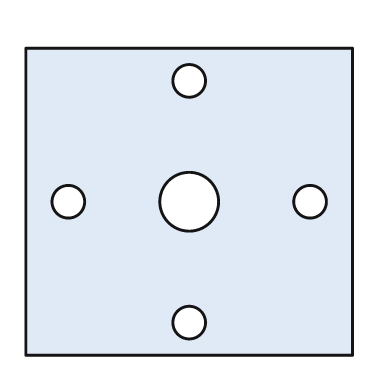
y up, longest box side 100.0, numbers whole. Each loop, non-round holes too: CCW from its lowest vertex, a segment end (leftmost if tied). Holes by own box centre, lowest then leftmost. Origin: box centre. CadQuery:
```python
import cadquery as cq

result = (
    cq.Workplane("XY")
    .moveTo(-50.0, -47.0)
    .lineTo(50.0, -47.0)
    .lineTo(50.0, 47.0)
    .lineTo(-50.0, 47.0)
    .close()
    .moveTo(0.0, -37.0)
    .circle(5.0)
    .moveTo(-37.0, 0.0)
    .circle(5.0)
    .moveTo(0.0, 0.0)
    .circle(9.0)
    .moveTo(37.0, 0.0)
    .circle(5.0)
    .moveTo(0.0, 37.0)
    .circle(5.0)
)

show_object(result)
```